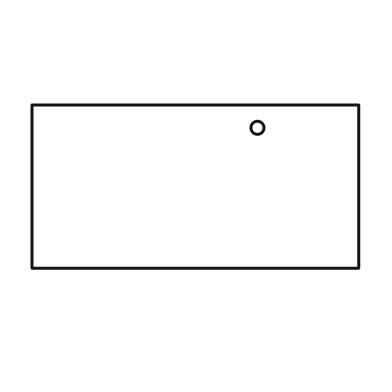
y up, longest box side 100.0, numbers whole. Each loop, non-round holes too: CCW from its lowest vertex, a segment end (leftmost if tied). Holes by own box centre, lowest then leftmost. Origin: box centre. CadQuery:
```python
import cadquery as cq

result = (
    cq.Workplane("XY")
    .moveTo(-50.0, -25.0)
    .lineTo(50.0, -25.0)
    .lineTo(50.0, 25.0)
    .lineTo(-50.0, 25.0)
    .close()
    .moveTo(19.0, 18.0)
    .circle(2.0)
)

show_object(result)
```